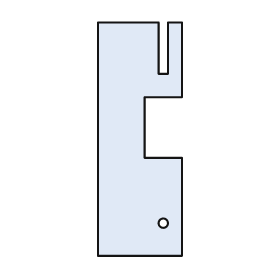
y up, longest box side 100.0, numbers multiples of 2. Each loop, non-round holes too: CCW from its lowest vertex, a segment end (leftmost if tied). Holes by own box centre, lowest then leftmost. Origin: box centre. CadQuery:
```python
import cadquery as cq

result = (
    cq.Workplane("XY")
    .moveTo(-18.0, -50.0)
    .lineTo(18.0, -50.0)
    .lineTo(18.0, -8.0)
    .lineTo(2.0, -8.0)
    .lineTo(2.0, 18.0)
    .lineTo(18.0, 18.0)
    .lineTo(18.0, 50.0)
    .lineTo(12.0, 50.0)
    .lineTo(12.0, 28.0)
    .lineTo(8.0, 28.0)
    .lineTo(8.0, 50.0)
    .lineTo(-18.0, 50.0)
    .close()
    .moveTo(10.0, -36.0)
    .circle(2.0)
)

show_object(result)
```